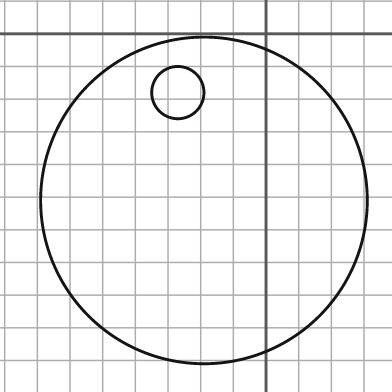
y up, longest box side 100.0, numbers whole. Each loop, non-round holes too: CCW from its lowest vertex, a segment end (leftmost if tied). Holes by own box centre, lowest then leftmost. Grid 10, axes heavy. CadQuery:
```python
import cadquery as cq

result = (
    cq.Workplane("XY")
    .moveTo(-19.0, -51.0)
    .circle(50.0)
    .moveTo(-27.0, -18.0)
    .circle(8.0)
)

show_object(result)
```